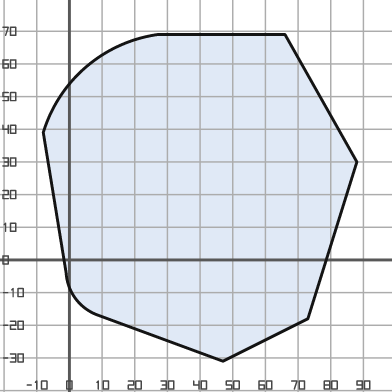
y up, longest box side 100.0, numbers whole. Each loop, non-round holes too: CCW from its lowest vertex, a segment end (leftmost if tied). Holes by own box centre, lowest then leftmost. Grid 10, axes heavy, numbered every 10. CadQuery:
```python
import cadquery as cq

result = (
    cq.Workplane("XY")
    .moveTo(47.0, -31.0)
    .lineTo(73.0, -18.0)
    .lineTo(88.0, 30.0)
    .lineTo(66.0, 69.0)
    .lineTo(27.0, 69.0)
    .threePointArc((5.0, 59.0), (-8.0, 39.0))
    .lineTo(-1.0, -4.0)
    .threePointArc((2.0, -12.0), (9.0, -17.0))
    .close()
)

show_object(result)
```